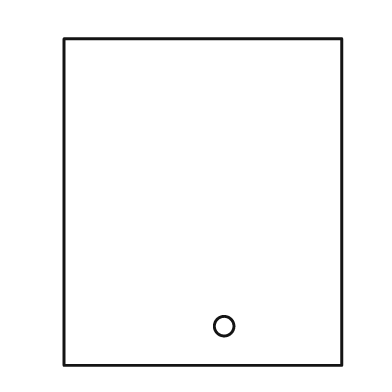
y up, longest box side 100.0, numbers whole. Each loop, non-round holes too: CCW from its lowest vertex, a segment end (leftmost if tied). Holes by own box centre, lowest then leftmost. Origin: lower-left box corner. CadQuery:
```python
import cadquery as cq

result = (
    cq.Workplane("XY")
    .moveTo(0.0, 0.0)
    .lineTo(85.0, 0.0)
    .lineTo(85.0, 100.0)
    .lineTo(0.0, 100.0)
    .close()
    .moveTo(49.0, 12.0)
    .circle(3.0)
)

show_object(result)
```